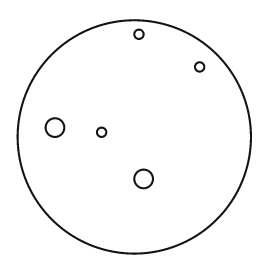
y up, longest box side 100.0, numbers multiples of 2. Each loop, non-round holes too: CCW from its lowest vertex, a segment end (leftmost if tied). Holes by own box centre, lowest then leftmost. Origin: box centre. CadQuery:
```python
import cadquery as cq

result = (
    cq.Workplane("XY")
    .moveTo(0.0, 0.0)
    .circle(50.0)
    .moveTo(4.0, -18.0)
    .circle(4.0)
    .moveTo(-14.0, 2.0)
    .circle(2.0)
    .moveTo(-34.0, 4.0)
    .circle(4.0)
    .moveTo(28.0, 30.0)
    .circle(2.0)
    .moveTo(2.0, 44.0)
    .circle(2.0)
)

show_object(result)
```